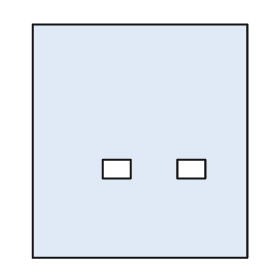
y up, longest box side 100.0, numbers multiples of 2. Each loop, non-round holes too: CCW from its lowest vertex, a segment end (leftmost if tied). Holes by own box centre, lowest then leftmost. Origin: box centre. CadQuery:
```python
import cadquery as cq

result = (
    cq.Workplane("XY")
    .moveTo(-46.0, -50.0)
    .lineTo(46.0, -50.0)
    .lineTo(46.0, 50.0)
    .lineTo(-46.0, 50.0)
    .close()
    .moveTo(-16.0, -16.0)
    .lineTo(-4.0, -16.0)
    .lineTo(-4.0, -8.0)
    .lineTo(-16.0, -8.0)
    .close()
    .moveTo(16.0, -16.0)
    .lineTo(28.0, -16.0)
    .lineTo(28.0, -8.0)
    .lineTo(16.0, -8.0)
    .close()
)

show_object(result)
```